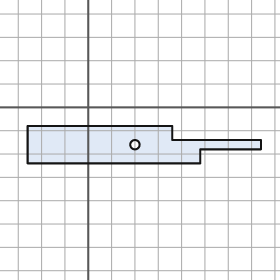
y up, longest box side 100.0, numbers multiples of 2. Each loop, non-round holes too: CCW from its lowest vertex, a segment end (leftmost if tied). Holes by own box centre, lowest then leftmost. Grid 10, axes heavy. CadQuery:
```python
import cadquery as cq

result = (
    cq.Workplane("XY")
    .moveTo(-26.0, -24.0)
    .lineTo(48.0, -24.0)
    .lineTo(48.0, -18.0)
    .lineTo(74.0, -18.0)
    .lineTo(74.0, -14.0)
    .lineTo(36.0, -14.0)
    .lineTo(36.0, -8.0)
    .lineTo(-26.0, -8.0)
    .close()
    .moveTo(20.0, -16.0)
    .circle(2.0)
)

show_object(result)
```